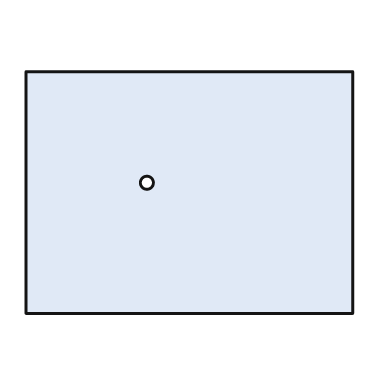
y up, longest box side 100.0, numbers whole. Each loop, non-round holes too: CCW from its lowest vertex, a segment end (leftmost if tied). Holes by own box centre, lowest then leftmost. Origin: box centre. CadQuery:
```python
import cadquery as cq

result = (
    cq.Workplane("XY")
    .moveTo(-50.0, -37.0)
    .lineTo(50.0, -37.0)
    .lineTo(50.0, 37.0)
    .lineTo(-50.0, 37.0)
    .close()
    .moveTo(-13.0, 3.0)
    .circle(2.0)
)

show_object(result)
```